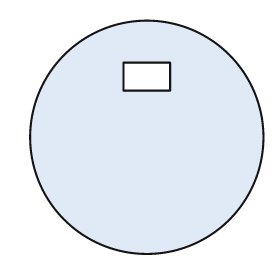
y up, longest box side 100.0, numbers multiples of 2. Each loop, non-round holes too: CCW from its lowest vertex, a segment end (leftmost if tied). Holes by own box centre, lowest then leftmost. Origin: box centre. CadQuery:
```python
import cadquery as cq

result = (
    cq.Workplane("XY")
    .moveTo(0.0, 0.0)
    .circle(50.0)
    .moveTo(-10.0, 20.0)
    .lineTo(10.0, 20.0)
    .lineTo(10.0, 32.0)
    .lineTo(-10.0, 32.0)
    .close()
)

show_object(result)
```